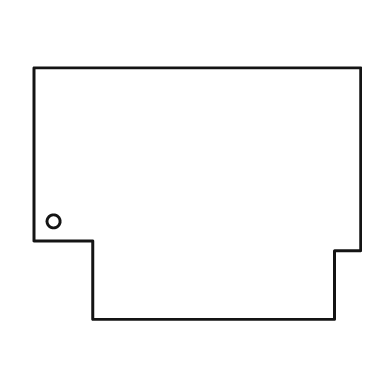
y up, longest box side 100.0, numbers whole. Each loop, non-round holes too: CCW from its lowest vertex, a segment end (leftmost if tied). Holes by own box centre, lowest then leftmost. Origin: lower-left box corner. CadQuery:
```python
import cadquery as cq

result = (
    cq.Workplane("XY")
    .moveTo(18.0, 0.0)
    .lineTo(92.0, 0.0)
    .lineTo(92.0, 21.0)
    .lineTo(100.0, 21.0)
    .lineTo(100.0, 77.0)
    .lineTo(0.0, 77.0)
    .lineTo(0.0, 24.0)
    .lineTo(18.0, 24.0)
    .close()
    .moveTo(6.0, 30.0)
    .circle(2.0)
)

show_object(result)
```